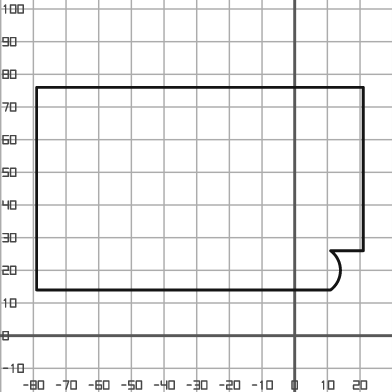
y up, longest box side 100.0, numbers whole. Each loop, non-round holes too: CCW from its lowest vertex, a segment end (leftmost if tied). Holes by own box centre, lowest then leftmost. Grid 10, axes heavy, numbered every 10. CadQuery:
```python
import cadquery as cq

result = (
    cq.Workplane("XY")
    .moveTo(-79.0, 14.0)
    .lineTo(11.0, 14.0)
    .threePointArc((14.0, 20.0), (11.0, 26.0))
    .lineTo(21.0, 26.0)
    .lineTo(21.0, 76.0)
    .lineTo(-79.0, 76.0)
    .close()
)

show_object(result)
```